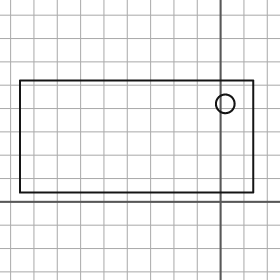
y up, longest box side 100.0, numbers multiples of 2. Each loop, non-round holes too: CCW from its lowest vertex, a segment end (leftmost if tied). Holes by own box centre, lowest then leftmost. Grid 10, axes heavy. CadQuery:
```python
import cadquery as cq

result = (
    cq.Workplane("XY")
    .moveTo(-86.0, 4.0)
    .lineTo(14.0, 4.0)
    .lineTo(14.0, 52.0)
    .lineTo(-86.0, 52.0)
    .close()
    .moveTo(2.0, 42.0)
    .circle(4.0)
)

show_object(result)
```